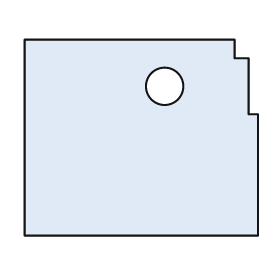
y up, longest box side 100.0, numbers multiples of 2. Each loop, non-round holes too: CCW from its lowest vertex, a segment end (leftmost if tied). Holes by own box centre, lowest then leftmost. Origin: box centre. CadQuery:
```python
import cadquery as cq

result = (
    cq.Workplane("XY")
    .moveTo(-50.0, -42.0)
    .lineTo(50.0, -42.0)
    .lineTo(50.0, 10.0)
    .lineTo(46.0, 10.0)
    .lineTo(46.0, 34.0)
    .lineTo(40.0, 34.0)
    .lineTo(40.0, 42.0)
    .lineTo(-50.0, 42.0)
    .close()
    .moveTo(10.0, 22.0)
    .circle(8.0)
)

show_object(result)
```